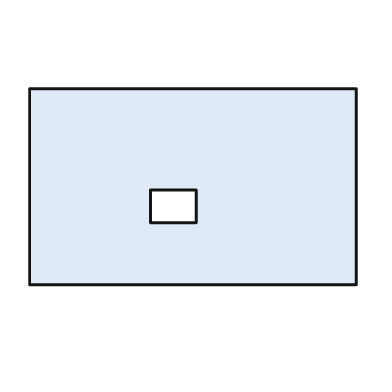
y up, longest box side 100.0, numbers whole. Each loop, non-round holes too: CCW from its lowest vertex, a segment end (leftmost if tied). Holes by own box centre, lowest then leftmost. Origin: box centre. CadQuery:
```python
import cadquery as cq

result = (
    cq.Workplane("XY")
    .moveTo(-50.0, -30.0)
    .lineTo(50.0, -30.0)
    .lineTo(50.0, 30.0)
    .lineTo(-50.0, 30.0)
    .close()
    .moveTo(-13.0, -11.0)
    .lineTo(1.0, -11.0)
    .lineTo(1.0, -1.0)
    .lineTo(-13.0, -1.0)
    .close()
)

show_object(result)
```